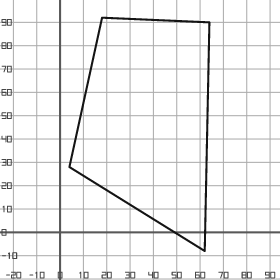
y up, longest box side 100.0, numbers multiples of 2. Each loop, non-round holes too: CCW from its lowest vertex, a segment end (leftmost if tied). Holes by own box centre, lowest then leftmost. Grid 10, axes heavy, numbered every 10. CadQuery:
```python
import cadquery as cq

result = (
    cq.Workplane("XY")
    .moveTo(62.0, -8.0)
    .lineTo(64.0, 90.0)
    .lineTo(18.0, 92.0)
    .lineTo(4.0, 28.0)
    .close()
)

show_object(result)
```